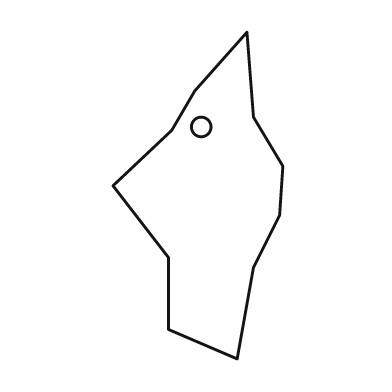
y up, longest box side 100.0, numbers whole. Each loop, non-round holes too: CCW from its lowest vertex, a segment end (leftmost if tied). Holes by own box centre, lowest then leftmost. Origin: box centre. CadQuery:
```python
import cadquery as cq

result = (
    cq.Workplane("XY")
    .moveTo(12.0, -50.0)
    .lineTo(17.0, -22.0)
    .lineTo(25.0, -6.0)
    .lineTo(26.0, 9.0)
    .lineTo(17.0, 24.0)
    .lineTo(15.0, 50.0)
    .lineTo(-1.0, 32.0)
    .lineTo(-8.0, 20.0)
    .lineTo(-26.0, 3.0)
    .lineTo(-9.0, -19.0)
    .lineTo(-9.0, -41.0)
    .close()
    .moveTo(1.0, 21.0)
    .circle(3.0)
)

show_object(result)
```